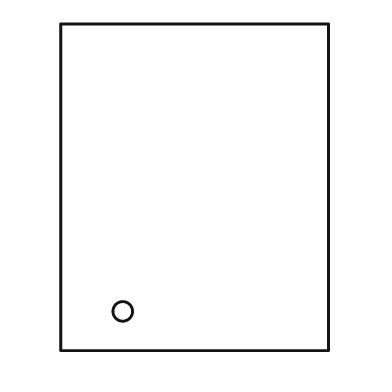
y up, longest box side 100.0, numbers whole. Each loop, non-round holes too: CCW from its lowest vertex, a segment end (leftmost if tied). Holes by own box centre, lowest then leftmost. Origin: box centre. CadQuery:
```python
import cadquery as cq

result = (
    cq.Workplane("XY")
    .moveTo(-41.0, -50.0)
    .lineTo(41.0, -50.0)
    .lineTo(41.0, 50.0)
    .lineTo(-41.0, 50.0)
    .close()
    .moveTo(-22.0, -38.0)
    .circle(3.0)
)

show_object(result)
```